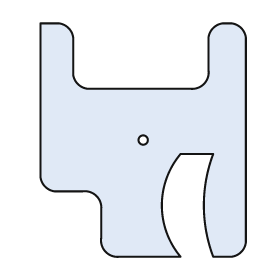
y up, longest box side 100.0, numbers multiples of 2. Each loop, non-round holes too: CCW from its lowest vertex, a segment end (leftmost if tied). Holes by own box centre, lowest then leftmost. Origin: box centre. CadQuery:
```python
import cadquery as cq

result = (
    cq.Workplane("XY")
    .moveTo(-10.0, -50.0)
    .lineTo(16.0, -50.0)
    .threePointArc((8.0, -28.0), (16.0, -6.0))
    .lineTo(30.0, -6.0)
    .threePointArc((26.0, -28.0), (30.0, -50.0))
    .lineTo(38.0, -50.0)
    .threePointArc((42.0, -48.0), (44.0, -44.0))
    .lineTo(44.0, 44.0)
    .threePointArc((42.0, 48.0), (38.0, 50.0))
    .lineTo(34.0, 50.0)
    .threePointArc((30.0, 48.0), (28.0, 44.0))
    .lineTo(28.0, 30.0)
    .threePointArc((26.0, 24.0), (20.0, 22.0))
    .lineTo(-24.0, 22.0)
    .threePointArc((-28.0, 24.0), (-30.0, 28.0))
    .lineTo(-30.0, 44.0)
    .threePointArc((-32.0, 48.0), (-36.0, 50.0))
    .lineTo(-44.0, 50.0)
    .lineTo(-44.0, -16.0)
    .threePointArc((-42.0, -20.0), (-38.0, -22.0))
    .lineTo(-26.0, -22.0)
    .threePointArc((-20.0, -24.0), (-18.0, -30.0))
    .lineTo(-18.0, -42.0)
    .threePointArc((-16.0, -48.0), (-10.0, -50.0))
    .close()
    .moveTo(0.0, 0.0)
    .circle(2.0)
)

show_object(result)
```